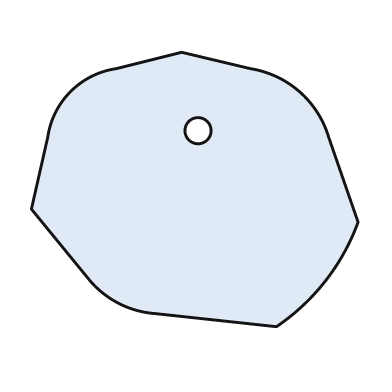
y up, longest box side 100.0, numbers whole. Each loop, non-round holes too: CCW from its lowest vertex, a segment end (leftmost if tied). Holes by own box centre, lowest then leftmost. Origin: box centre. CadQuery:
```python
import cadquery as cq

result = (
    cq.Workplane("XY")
    .moveTo(25.0, -42.0)
    .threePointArc((40.0, -28.0), (50.0, -10.0))
    .lineTo(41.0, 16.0)
    .threePointArc((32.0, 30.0), (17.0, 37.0))
    .lineTo(-4.0, 42.0)
    .lineTo(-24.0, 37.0)
    .threePointArc((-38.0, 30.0), (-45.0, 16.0))
    .lineTo(-50.0, -6.0)
    .lineTo(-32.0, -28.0)
    .threePointArc((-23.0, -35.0), (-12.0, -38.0))
    .close()
    .moveTo(1.0, 18.0)
    .circle(4.0)
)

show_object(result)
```